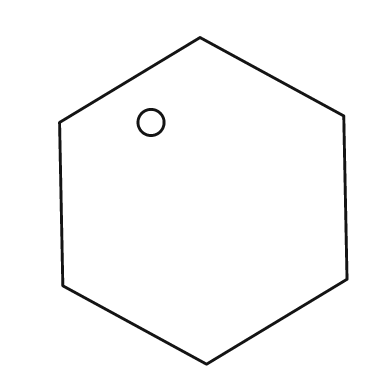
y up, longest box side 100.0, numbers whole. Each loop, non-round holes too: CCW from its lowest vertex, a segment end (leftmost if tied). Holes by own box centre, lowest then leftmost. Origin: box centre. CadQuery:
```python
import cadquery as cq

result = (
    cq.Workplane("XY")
    .moveTo(1.0, -50.0)
    .lineTo(44.0, -24.0)
    .lineTo(43.0, 26.0)
    .lineTo(-1.0, 50.0)
    .lineTo(-44.0, 24.0)
    .lineTo(-43.0, -26.0)
    .close()
    .moveTo(-16.0, 24.0)
    .circle(4.0)
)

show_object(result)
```